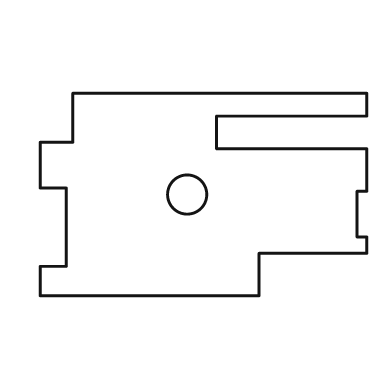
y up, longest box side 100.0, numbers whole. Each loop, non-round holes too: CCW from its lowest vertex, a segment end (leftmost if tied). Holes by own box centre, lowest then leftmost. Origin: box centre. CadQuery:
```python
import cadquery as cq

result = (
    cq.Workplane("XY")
    .moveTo(-50.0, -31.0)
    .lineTo(17.0, -31.0)
    .lineTo(17.0, -18.0)
    .lineTo(50.0, -18.0)
    .lineTo(50.0, -13.0)
    .lineTo(47.0, -13.0)
    .lineTo(47.0, 1.0)
    .lineTo(50.0, 1.0)
    .lineTo(50.0, 14.0)
    .lineTo(4.0, 14.0)
    .lineTo(4.0, 24.0)
    .lineTo(50.0, 24.0)
    .lineTo(50.0, 31.0)
    .lineTo(-40.0, 31.0)
    .lineTo(-40.0, 16.0)
    .lineTo(-50.0, 16.0)
    .lineTo(-50.0, 2.0)
    .lineTo(-42.0, 2.0)
    .lineTo(-42.0, -22.0)
    .lineTo(-50.0, -22.0)
    .close()
    .moveTo(-5.0, 0.0)
    .circle(6.0)
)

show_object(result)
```